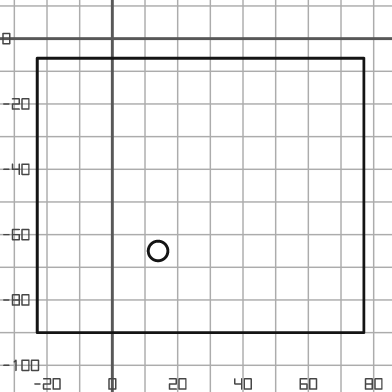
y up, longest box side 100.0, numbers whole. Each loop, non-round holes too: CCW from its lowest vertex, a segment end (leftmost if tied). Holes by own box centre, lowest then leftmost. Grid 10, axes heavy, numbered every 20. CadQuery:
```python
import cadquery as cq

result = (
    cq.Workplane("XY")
    .moveTo(-23.0, -90.0)
    .lineTo(77.0, -90.0)
    .lineTo(77.0, -6.0)
    .lineTo(-23.0, -6.0)
    .close()
    .moveTo(14.0, -65.0)
    .circle(3.0)
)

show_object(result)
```